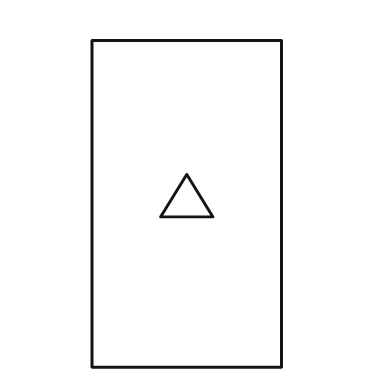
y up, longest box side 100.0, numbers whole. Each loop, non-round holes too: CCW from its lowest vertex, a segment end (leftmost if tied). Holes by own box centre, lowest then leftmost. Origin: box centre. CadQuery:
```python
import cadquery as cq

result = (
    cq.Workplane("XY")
    .moveTo(-29.0, -50.0)
    .lineTo(29.0, -50.0)
    .lineTo(29.0, 50.0)
    .lineTo(-29.0, 50.0)
    .close()
    .moveTo(-8.0, -4.0)
    .lineTo(8.0, -4.0)
    .lineTo(0.0, 9.0)
    .close()
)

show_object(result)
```